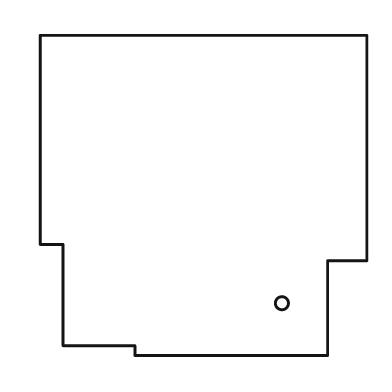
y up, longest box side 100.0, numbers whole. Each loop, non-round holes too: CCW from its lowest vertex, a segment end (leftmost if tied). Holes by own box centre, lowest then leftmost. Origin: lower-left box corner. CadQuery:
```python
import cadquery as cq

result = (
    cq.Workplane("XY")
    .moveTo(29.0, 0.0)
    .lineTo(88.0, 0.0)
    .lineTo(88.0, 29.0)
    .lineTo(100.0, 29.0)
    .lineTo(100.0, 98.0)
    .lineTo(0.0, 98.0)
    .lineTo(0.0, 34.0)
    .lineTo(7.0, 34.0)
    .lineTo(7.0, 3.0)
    .lineTo(29.0, 3.0)
    .close()
    .moveTo(74.0, 16.0)
    .circle(2.0)
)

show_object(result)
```